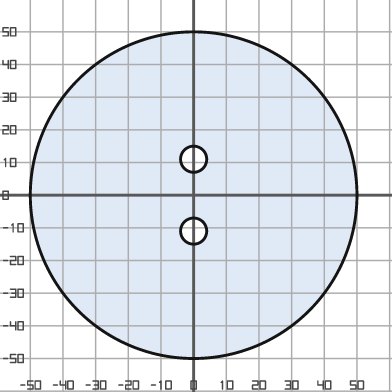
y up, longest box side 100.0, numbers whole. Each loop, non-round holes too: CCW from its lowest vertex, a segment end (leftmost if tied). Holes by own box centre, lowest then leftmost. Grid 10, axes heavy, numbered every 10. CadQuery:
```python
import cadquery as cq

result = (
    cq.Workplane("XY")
    .moveTo(0.0, 0.0)
    .circle(50.0)
    .moveTo(0.0, -11.0)
    .circle(4.0)
    .moveTo(0.0, 11.0)
    .circle(4.0)
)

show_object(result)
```